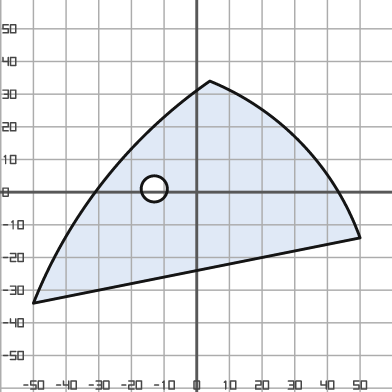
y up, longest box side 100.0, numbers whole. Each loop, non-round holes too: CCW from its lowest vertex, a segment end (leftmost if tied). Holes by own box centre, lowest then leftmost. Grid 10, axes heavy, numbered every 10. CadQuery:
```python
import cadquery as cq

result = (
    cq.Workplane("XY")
    .moveTo(-50.0, -34.0)
    .lineTo(50.0, -14.0)
    .threePointArc((32.0, 15.0), (4.0, 34.0))
    .threePointArc((-28.0, 4.0), (-50.0, -34.0))
    .close()
    .moveTo(-13.0, 1.0)
    .circle(4.0)
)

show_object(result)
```